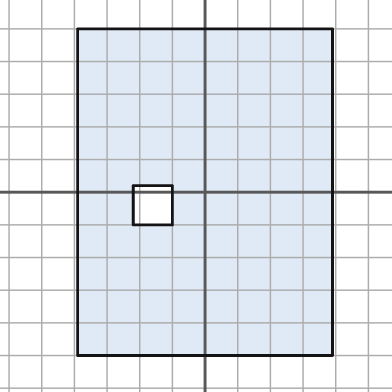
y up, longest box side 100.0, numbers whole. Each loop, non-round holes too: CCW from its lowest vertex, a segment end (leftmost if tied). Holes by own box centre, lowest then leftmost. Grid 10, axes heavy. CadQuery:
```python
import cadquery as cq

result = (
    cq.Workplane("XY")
    .moveTo(-39.0, -50.0)
    .lineTo(39.0, -50.0)
    .lineTo(39.0, 50.0)
    .lineTo(-39.0, 50.0)
    .close()
    .moveTo(-22.0, -10.0)
    .lineTo(-10.0, -10.0)
    .lineTo(-10.0, 2.0)
    .lineTo(-22.0, 2.0)
    .close()
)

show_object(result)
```